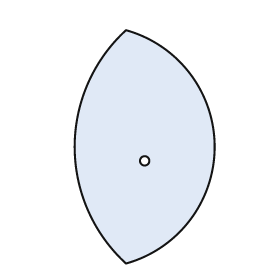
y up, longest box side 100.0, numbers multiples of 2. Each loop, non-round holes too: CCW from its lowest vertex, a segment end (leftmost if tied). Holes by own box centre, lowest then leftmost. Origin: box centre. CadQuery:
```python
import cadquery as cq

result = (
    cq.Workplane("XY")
    .moveTo(-8.0, -50.0)
    .threePointArc((30.0, 0.0), (-8.0, 50.0))
    .threePointArc((-30.0, 0.0), (-8.0, -50.0))
    .close()
    .moveTo(0.0, -6.0)
    .circle(2.0)
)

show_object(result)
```